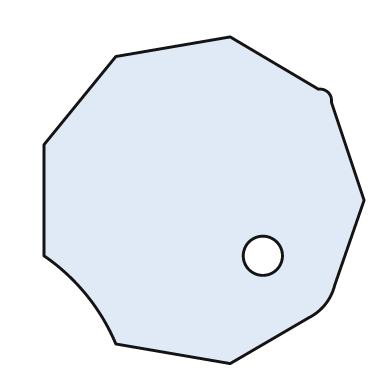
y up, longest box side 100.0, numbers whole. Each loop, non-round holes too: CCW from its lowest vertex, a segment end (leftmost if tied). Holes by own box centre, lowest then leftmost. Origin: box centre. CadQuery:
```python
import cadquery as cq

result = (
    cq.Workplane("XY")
    .moveTo(8.0, -50.0)
    .lineTo(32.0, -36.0)
    .threePointArc((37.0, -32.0), (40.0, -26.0))
    .lineTo(49.0, 0.0)
    .lineTo(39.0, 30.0)
    .threePointArc((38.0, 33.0), (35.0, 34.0))
    .lineTo(8.0, 50.0)
    .lineTo(-27.0, 44.0)
    .lineTo(-49.0, 17.0)
    .lineTo(-49.0, -17.0)
    .threePointArc((-36.0, -29.0), (-27.0, -44.0))
    .close()
    .moveTo(18.0, -17.0)
    .circle(6.0)
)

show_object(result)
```